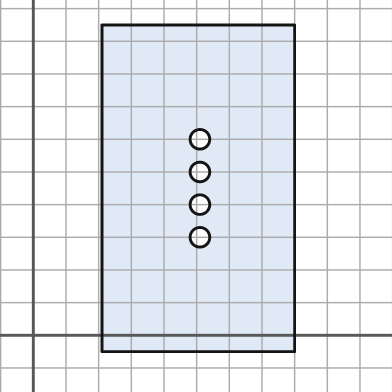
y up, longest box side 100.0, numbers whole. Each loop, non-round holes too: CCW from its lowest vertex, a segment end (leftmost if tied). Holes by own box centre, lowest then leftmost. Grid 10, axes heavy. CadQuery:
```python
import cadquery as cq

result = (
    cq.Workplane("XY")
    .moveTo(21.0, -5.0)
    .lineTo(80.0, -5.0)
    .lineTo(80.0, 95.0)
    .lineTo(21.0, 95.0)
    .close()
    .moveTo(51.0, 30.0)
    .circle(3.0)
    .moveTo(51.0, 40.0)
    .circle(3.0)
    .moveTo(51.0, 50.0)
    .circle(3.0)
    .moveTo(51.0, 60.0)
    .circle(3.0)
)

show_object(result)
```